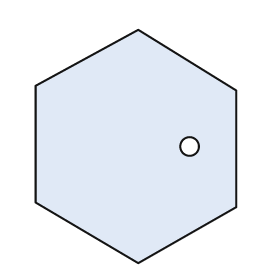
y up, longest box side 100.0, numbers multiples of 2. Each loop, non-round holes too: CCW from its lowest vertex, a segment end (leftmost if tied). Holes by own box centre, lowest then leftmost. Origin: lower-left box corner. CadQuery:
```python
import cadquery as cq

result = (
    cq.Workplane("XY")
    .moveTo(44.0, 0.0)
    .lineTo(86.0, 24.0)
    .lineTo(86.0, 74.0)
    .lineTo(44.0, 100.0)
    .lineTo(0.0, 76.0)
    .lineTo(0.0, 26.0)
    .close()
    .moveTo(66.0, 50.0)
    .circle(4.0)
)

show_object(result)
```